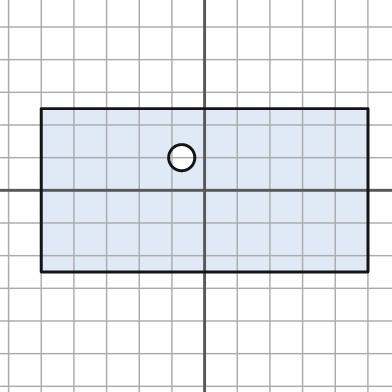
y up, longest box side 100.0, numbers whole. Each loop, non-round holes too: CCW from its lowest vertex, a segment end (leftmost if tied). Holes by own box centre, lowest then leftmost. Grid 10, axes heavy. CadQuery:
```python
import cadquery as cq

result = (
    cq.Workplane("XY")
    .moveTo(-50.0, -25.0)
    .lineTo(50.0, -25.0)
    .lineTo(50.0, 25.0)
    .lineTo(-50.0, 25.0)
    .close()
    .moveTo(-7.0, 10.0)
    .circle(4.0)
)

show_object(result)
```